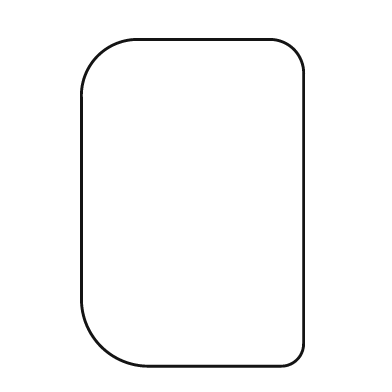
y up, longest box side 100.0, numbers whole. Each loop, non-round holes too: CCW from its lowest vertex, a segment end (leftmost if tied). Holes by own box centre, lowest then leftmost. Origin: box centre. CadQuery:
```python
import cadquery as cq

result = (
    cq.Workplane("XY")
    .moveTo(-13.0, -50.0)
    .lineTo(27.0, -50.0)
    .threePointArc((32.0, -48.0), (34.0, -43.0))
    .lineTo(34.0, 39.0)
    .threePointArc((31.0, 47.0), (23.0, 50.0))
    .lineTo(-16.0, 50.0)
    .threePointArc((-29.0, 45.0), (-34.0, 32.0))
    .lineTo(-34.0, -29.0)
    .threePointArc((-28.0, -44.0), (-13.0, -50.0))
    .close()
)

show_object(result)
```